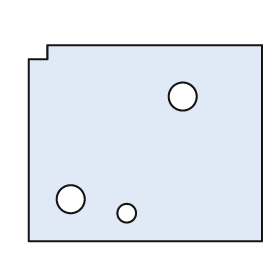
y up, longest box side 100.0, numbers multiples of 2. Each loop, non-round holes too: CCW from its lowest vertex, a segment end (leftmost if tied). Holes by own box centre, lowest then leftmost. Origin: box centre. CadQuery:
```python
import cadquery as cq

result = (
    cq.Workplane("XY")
    .moveTo(-50.0, -42.0)
    .lineTo(50.0, -42.0)
    .lineTo(50.0, 42.0)
    .lineTo(-42.0, 42.0)
    .lineTo(-42.0, 36.0)
    .lineTo(-50.0, 36.0)
    .close()
    .moveTo(-8.0, -30.0)
    .circle(4.0)
    .moveTo(-32.0, -24.0)
    .circle(6.0)
    .moveTo(16.0, 20.0)
    .circle(6.0)
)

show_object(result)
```